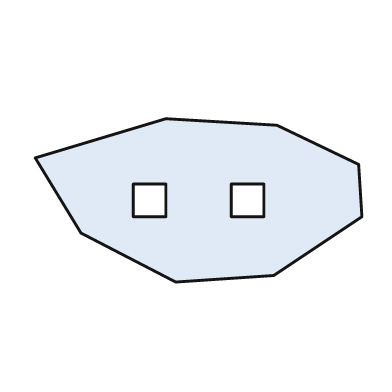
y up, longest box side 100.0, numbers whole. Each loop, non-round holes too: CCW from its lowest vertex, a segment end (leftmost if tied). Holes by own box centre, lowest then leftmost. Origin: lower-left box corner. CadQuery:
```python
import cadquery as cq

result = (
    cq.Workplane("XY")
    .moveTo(43.0, 0.0)
    .lineTo(73.0, 2.0)
    .lineTo(100.0, 20.0)
    .lineTo(99.0, 36.0)
    .lineTo(74.0, 48.0)
    .lineTo(40.0, 50.0)
    .lineTo(0.0, 38.0)
    .lineTo(14.0, 15.0)
    .close()
    .moveTo(30.0, 20.0)
    .lineTo(40.0, 20.0)
    .lineTo(40.0, 30.0)
    .lineTo(30.0, 30.0)
    .close()
    .moveTo(60.0, 20.0)
    .lineTo(70.0, 20.0)
    .lineTo(70.0, 30.0)
    .lineTo(60.0, 30.0)
    .close()
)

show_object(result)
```